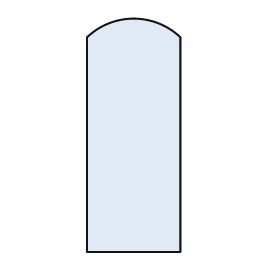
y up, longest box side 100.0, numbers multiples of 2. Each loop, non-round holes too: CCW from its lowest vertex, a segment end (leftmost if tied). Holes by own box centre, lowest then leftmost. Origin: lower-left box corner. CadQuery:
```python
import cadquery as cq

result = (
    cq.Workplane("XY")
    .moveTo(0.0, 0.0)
    .lineTo(40.0, 0.0)
    .lineTo(40.0, 92.0)
    .threePointArc((20.0, 100.0), (0.0, 92.0))
    .close()
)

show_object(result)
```